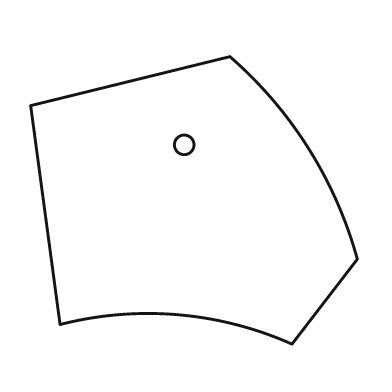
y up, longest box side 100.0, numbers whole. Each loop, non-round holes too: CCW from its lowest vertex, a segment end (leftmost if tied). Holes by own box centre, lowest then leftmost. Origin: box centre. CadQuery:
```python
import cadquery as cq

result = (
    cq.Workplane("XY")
    .moveTo(30.0, -44.0)
    .lineTo(50.0, -18.0)
    .threePointArc((35.0, 16.0), (11.0, 44.0))
    .lineTo(-50.0, 29.0)
    .lineTo(-41.0, -38.0)
    .threePointArc((-5.0, -35.0), (30.0, -44.0))
    .close()
    .moveTo(-3.0, 17.0)
    .circle(3.0)
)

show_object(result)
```